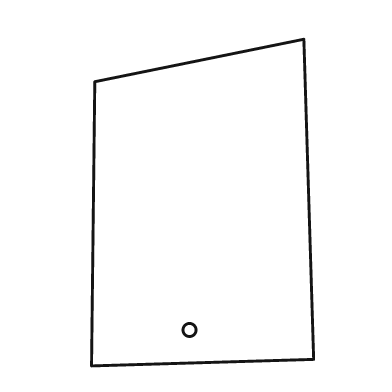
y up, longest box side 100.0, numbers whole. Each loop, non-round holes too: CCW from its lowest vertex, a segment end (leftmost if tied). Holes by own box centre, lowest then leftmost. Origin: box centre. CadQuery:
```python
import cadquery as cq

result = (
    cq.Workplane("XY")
    .moveTo(-34.0, -50.0)
    .lineTo(34.0, -48.0)
    .lineTo(31.0, 50.0)
    .lineTo(-33.0, 37.0)
    .close()
    .moveTo(-4.0, -39.0)
    .circle(2.0)
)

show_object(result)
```